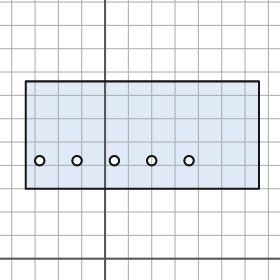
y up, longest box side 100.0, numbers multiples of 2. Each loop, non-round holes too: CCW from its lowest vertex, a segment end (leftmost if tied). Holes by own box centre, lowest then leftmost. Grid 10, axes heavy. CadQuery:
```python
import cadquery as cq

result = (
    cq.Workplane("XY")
    .moveTo(-34.0, 30.0)
    .lineTo(66.0, 30.0)
    .lineTo(66.0, 76.0)
    .lineTo(-34.0, 76.0)
    .close()
    .moveTo(-28.0, 42.0)
    .circle(2.0)
    .moveTo(-12.0, 42.0)
    .circle(2.0)
    .moveTo(4.0, 42.0)
    .circle(2.0)
    .moveTo(20.0, 42.0)
    .circle(2.0)
    .moveTo(36.0, 42.0)
    .circle(2.0)
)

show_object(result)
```